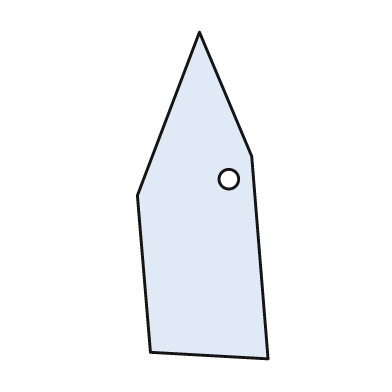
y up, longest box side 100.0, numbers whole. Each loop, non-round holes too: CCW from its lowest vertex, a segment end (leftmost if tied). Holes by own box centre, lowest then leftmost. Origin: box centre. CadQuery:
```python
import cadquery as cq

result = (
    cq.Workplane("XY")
    .moveTo(20.0, -50.0)
    .lineTo(15.0, 12.0)
    .lineTo(-1.0, 50.0)
    .lineTo(-20.0, 0.0)
    .lineTo(-16.0, -48.0)
    .close()
    .moveTo(8.0, 5.0)
    .circle(3.0)
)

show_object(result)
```